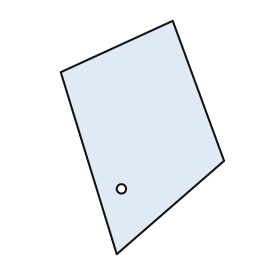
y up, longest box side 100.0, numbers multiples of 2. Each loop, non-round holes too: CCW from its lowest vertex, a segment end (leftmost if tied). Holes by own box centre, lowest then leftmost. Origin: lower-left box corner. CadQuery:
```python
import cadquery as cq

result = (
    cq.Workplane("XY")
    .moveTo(24.0, 0.0)
    .lineTo(70.0, 40.0)
    .lineTo(48.0, 100.0)
    .lineTo(0.0, 78.0)
    .close()
    .moveTo(26.0, 28.0)
    .circle(2.0)
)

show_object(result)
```